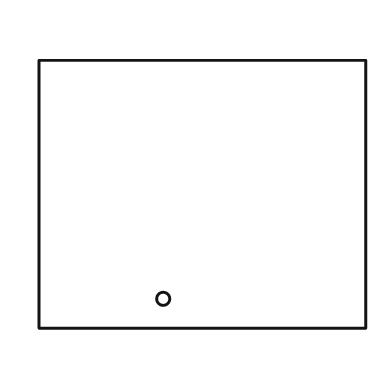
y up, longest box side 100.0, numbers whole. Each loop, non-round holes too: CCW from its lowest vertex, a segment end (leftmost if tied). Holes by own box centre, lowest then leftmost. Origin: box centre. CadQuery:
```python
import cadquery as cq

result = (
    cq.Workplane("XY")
    .moveTo(-50.0, -41.0)
    .lineTo(50.0, -41.0)
    .lineTo(50.0, 41.0)
    .lineTo(-50.0, 41.0)
    .close()
    .moveTo(-12.0, -32.0)
    .circle(2.0)
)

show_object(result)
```